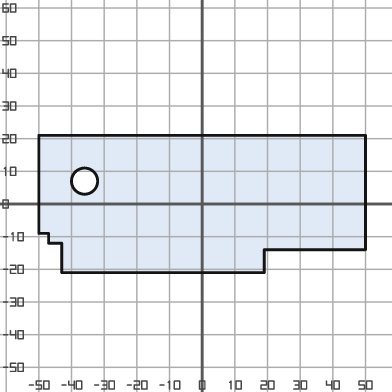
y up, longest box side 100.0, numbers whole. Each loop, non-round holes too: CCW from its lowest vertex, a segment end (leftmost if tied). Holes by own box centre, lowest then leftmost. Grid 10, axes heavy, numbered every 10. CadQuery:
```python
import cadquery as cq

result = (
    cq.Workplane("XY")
    .moveTo(-43.0, -21.0)
    .lineTo(19.0, -21.0)
    .lineTo(19.0, -14.0)
    .lineTo(50.0, -14.0)
    .lineTo(50.0, 21.0)
    .lineTo(-50.0, 21.0)
    .lineTo(-50.0, -9.0)
    .lineTo(-47.0, -9.0)
    .lineTo(-47.0, -12.0)
    .lineTo(-43.0, -12.0)
    .close()
    .moveTo(-36.0, 7.0)
    .circle(4.0)
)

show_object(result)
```